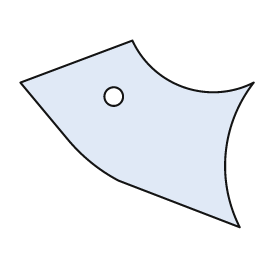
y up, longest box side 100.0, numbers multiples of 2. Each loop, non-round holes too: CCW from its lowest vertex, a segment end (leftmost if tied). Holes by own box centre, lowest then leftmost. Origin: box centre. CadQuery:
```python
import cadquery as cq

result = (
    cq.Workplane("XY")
    .moveTo(44.0, -40.0)
    .threePointArc((38.0, -8.0), (50.0, 22.0))
    .threePointArc((20.0, 20.0), (-2.0, 40.0))
    .lineTo(-50.0, 22.0)
    .lineTo(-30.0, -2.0)
    .threePointArc((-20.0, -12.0), (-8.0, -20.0))
    .close()
    .moveTo(-10.0, 16.0)
    .circle(4.0)
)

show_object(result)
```